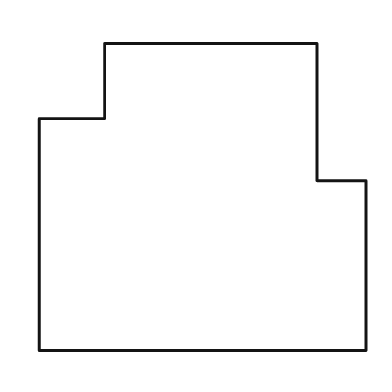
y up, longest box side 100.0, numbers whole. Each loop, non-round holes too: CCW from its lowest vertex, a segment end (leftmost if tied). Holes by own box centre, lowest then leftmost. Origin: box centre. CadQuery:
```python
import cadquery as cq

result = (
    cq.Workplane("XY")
    .moveTo(-50.0, -47.0)
    .lineTo(50.0, -47.0)
    .lineTo(50.0, 5.0)
    .lineTo(35.0, 5.0)
    .lineTo(35.0, 47.0)
    .lineTo(-30.0, 47.0)
    .lineTo(-30.0, 24.0)
    .lineTo(-50.0, 24.0)
    .close()
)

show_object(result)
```